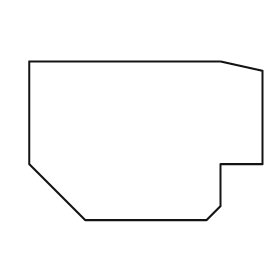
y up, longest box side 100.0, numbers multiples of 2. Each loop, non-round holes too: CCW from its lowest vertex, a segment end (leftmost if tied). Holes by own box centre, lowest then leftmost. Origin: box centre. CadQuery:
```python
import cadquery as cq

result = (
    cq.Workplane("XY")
    .moveTo(-26.0, -34.0)
    .lineTo(26.0, -34.0)
    .lineTo(32.0, -28.0)
    .lineTo(32.0, -10.0)
    .lineTo(50.0, -10.0)
    .lineTo(50.0, 30.0)
    .lineTo(32.0, 34.0)
    .lineTo(-50.0, 34.0)
    .lineTo(-50.0, -10.0)
    .close()
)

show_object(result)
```